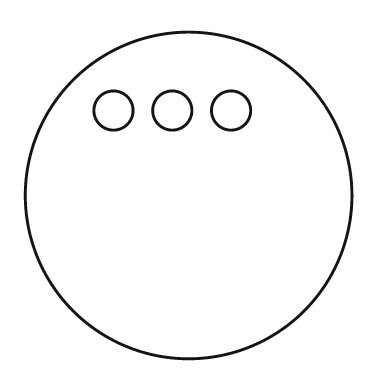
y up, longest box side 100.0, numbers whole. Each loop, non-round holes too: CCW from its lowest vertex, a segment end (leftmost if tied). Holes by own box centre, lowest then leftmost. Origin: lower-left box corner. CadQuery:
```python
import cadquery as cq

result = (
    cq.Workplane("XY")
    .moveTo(50.0, 50.0)
    .circle(50.0)
    .moveTo(27.0, 76.0)
    .circle(6.0)
    .moveTo(45.0, 76.0)
    .circle(6.0)
    .moveTo(63.0, 76.0)
    .circle(6.0)
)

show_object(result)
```